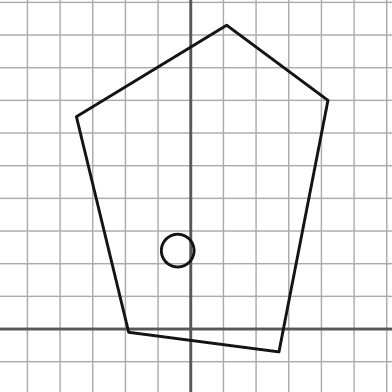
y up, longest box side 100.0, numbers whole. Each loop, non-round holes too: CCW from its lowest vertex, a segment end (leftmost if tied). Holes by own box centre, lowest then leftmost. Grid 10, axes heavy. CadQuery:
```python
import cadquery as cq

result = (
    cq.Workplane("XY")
    .moveTo(27.0, -7.0)
    .lineTo(42.0, 70.0)
    .lineTo(11.0, 93.0)
    .lineTo(-35.0, 65.0)
    .lineTo(-19.0, -1.0)
    .close()
    .moveTo(-4.0, 24.0)
    .circle(5.0)
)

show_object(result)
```